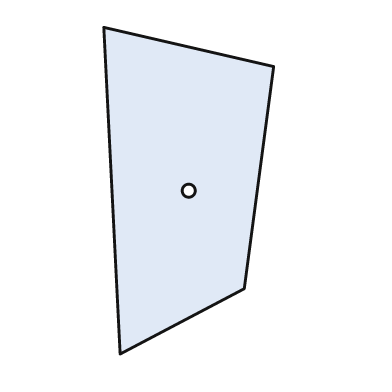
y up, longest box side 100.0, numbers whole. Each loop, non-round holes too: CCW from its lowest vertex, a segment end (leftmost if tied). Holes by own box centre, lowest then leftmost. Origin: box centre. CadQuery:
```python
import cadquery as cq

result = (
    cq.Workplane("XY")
    .moveTo(-21.0, -50.0)
    .lineTo(17.0, -30.0)
    .lineTo(26.0, 38.0)
    .lineTo(-26.0, 50.0)
    .close()
    .moveTo(0.0, 0.0)
    .circle(2.0)
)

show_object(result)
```